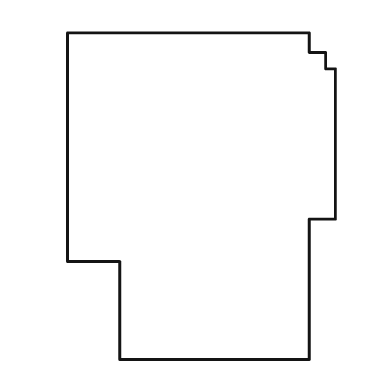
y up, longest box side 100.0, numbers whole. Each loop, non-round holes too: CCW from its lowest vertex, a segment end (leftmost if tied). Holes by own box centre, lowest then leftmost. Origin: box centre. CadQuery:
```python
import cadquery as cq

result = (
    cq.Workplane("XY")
    .moveTo(-25.0, -50.0)
    .lineTo(33.0, -50.0)
    .lineTo(33.0, -7.0)
    .lineTo(41.0, -7.0)
    .lineTo(41.0, 39.0)
    .lineTo(38.0, 39.0)
    .lineTo(38.0, 44.0)
    .lineTo(33.0, 44.0)
    .lineTo(33.0, 50.0)
    .lineTo(-41.0, 50.0)
    .lineTo(-41.0, -20.0)
    .lineTo(-25.0, -20.0)
    .close()
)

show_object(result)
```